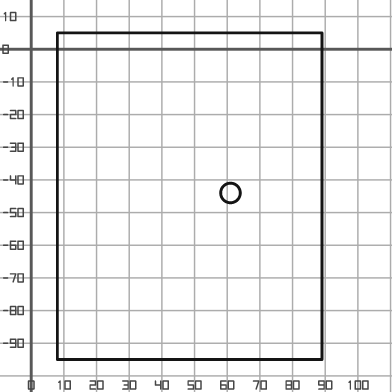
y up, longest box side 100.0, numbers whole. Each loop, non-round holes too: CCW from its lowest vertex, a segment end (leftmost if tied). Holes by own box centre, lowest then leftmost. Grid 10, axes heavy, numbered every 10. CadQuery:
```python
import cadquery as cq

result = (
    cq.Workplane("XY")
    .moveTo(8.0, -95.0)
    .lineTo(89.0, -95.0)
    .lineTo(89.0, 5.0)
    .lineTo(8.0, 5.0)
    .close()
    .moveTo(61.0, -44.0)
    .circle(3.0)
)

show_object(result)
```